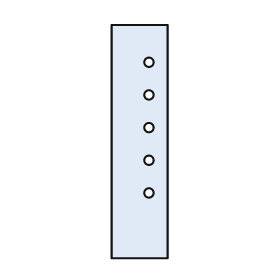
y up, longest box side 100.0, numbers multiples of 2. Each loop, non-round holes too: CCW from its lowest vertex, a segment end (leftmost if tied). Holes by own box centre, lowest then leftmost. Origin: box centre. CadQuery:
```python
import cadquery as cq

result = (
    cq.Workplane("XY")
    .moveTo(-12.0, -50.0)
    .lineTo(12.0, -50.0)
    .lineTo(12.0, 50.0)
    .lineTo(-12.0, 50.0)
    .close()
    .moveTo(4.0, -22.0)
    .circle(2.0)
    .moveTo(4.0, -8.0)
    .circle(2.0)
    .moveTo(4.0, 6.0)
    .circle(2.0)
    .moveTo(4.0, 20.0)
    .circle(2.0)
    .moveTo(4.0, 34.0)
    .circle(2.0)
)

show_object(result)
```